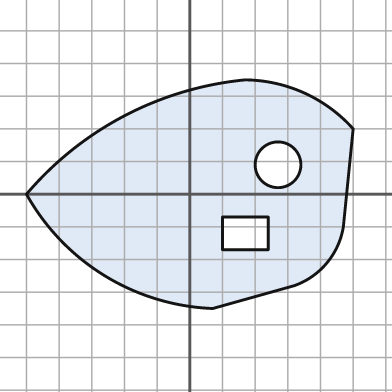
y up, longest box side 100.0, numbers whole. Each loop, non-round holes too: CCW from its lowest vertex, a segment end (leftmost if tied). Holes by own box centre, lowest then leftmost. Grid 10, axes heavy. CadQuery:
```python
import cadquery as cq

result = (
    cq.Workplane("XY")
    .moveTo(7.0, -35.0)
    .lineTo(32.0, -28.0)
    .threePointArc((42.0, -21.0), (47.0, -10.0))
    .lineTo(50.0, 20.0)
    .threePointArc((35.0, 31.0), (17.0, 35.0))
    .threePointArc((-20.0, 24.0), (-50.0, 0.0))
    .threePointArc((-26.0, -25.0), (7.0, -35.0))
    .close()
    .moveTo(10.0, -17.0)
    .lineTo(24.0, -17.0)
    .lineTo(24.0, -7.0)
    .lineTo(10.0, -7.0)
    .close()
    .moveTo(27.0, 9.0)
    .circle(7.0)
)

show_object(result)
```